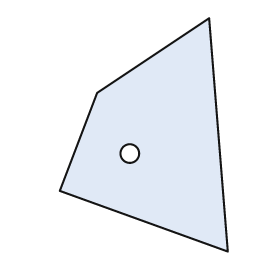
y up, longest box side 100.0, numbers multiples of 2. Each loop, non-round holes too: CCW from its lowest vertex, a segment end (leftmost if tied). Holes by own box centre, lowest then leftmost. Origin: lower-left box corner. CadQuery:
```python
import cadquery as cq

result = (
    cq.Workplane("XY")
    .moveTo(72.0, 0.0)
    .lineTo(64.0, 100.0)
    .lineTo(16.0, 68.0)
    .lineTo(0.0, 26.0)
    .close()
    .moveTo(30.0, 42.0)
    .circle(4.0)
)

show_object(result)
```